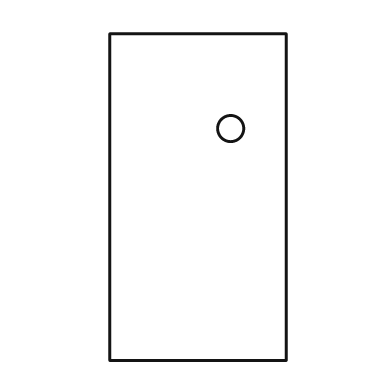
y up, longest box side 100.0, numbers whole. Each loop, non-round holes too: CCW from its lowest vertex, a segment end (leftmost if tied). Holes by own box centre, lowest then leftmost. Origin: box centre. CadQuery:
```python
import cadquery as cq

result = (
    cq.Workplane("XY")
    .moveTo(-27.0, -50.0)
    .lineTo(27.0, -50.0)
    .lineTo(27.0, 50.0)
    .lineTo(-27.0, 50.0)
    .close()
    .moveTo(10.0, 21.0)
    .circle(4.0)
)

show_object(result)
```